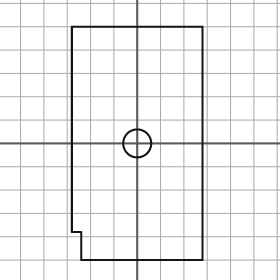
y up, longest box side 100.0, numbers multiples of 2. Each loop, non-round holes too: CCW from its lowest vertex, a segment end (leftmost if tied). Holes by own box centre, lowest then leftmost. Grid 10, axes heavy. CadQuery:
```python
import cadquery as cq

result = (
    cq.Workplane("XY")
    .moveTo(-24.0, -50.0)
    .lineTo(28.0, -50.0)
    .lineTo(28.0, 50.0)
    .lineTo(-28.0, 50.0)
    .lineTo(-28.0, -38.0)
    .lineTo(-24.0, -38.0)
    .close()
    .moveTo(0.0, 0.0)
    .circle(6.0)
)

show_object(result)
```